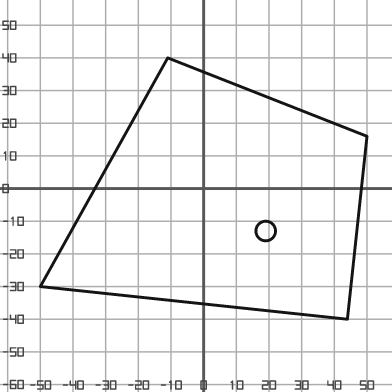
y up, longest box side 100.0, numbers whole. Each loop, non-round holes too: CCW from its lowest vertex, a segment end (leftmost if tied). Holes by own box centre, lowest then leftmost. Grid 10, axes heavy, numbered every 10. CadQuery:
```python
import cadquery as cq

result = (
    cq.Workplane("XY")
    .moveTo(44.0, -40.0)
    .lineTo(50.0, 16.0)
    .lineTo(-11.0, 40.0)
    .lineTo(-50.0, -30.0)
    .close()
    .moveTo(19.0, -13.0)
    .circle(3.0)
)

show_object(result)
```